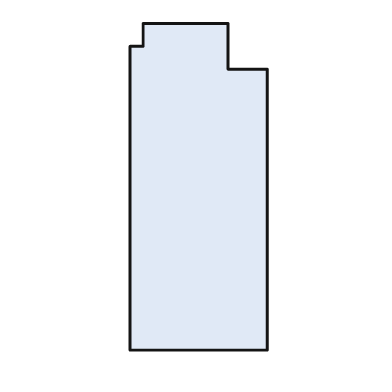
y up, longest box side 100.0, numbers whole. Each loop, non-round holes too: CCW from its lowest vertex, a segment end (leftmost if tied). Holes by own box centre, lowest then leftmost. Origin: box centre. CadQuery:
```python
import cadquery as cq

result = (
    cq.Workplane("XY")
    .moveTo(-21.0, -50.0)
    .lineTo(21.0, -50.0)
    .lineTo(21.0, 36.0)
    .lineTo(9.0, 36.0)
    .lineTo(9.0, 50.0)
    .lineTo(-17.0, 50.0)
    .lineTo(-17.0, 43.0)
    .lineTo(-21.0, 43.0)
    .close()
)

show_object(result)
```